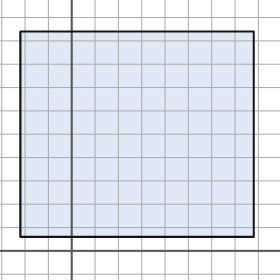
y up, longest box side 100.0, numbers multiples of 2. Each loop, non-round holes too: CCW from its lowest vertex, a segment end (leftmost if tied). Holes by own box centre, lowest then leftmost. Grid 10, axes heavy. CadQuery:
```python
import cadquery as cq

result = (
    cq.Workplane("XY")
    .moveTo(-22.0, 6.0)
    .lineTo(78.0, 6.0)
    .lineTo(78.0, 94.0)
    .lineTo(-22.0, 94.0)
    .close()
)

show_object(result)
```